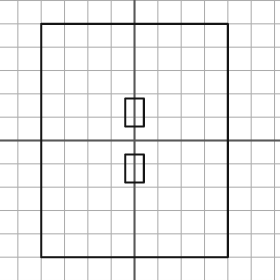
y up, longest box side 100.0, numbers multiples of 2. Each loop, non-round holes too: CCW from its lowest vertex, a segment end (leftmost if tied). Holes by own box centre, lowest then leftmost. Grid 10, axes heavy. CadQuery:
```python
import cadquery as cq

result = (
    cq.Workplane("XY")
    .moveTo(-40.0, -50.0)
    .lineTo(40.0, -50.0)
    .lineTo(40.0, 50.0)
    .lineTo(-40.0, 50.0)
    .close()
    .moveTo(-4.0, -18.0)
    .lineTo(4.0, -18.0)
    .lineTo(4.0, -6.0)
    .lineTo(-4.0, -6.0)
    .close()
    .moveTo(-4.0, 6.0)
    .lineTo(4.0, 6.0)
    .lineTo(4.0, 18.0)
    .lineTo(-4.0, 18.0)
    .close()
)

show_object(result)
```